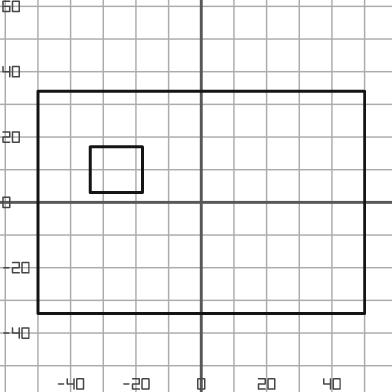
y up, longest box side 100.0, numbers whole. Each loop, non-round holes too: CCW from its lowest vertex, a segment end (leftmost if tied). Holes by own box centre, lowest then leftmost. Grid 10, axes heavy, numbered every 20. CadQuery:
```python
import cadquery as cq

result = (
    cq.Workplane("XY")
    .moveTo(-50.0, -34.0)
    .lineTo(50.0, -34.0)
    .lineTo(50.0, 34.0)
    .lineTo(-50.0, 34.0)
    .close()
    .moveTo(-34.0, 3.0)
    .lineTo(-18.0, 3.0)
    .lineTo(-18.0, 17.0)
    .lineTo(-34.0, 17.0)
    .close()
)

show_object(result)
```